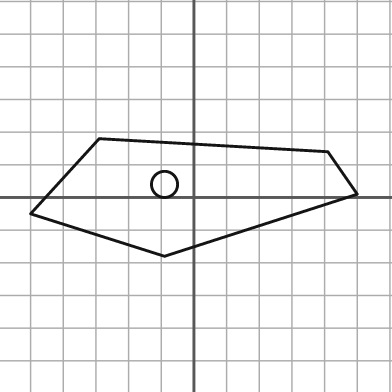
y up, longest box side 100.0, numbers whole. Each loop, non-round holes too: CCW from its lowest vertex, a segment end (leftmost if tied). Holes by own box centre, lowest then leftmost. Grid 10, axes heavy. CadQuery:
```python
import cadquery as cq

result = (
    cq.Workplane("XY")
    .moveTo(-9.0, -18.0)
    .lineTo(50.0, 1.0)
    .lineTo(41.0, 14.0)
    .lineTo(-29.0, 18.0)
    .lineTo(-50.0, -5.0)
    .close()
    .moveTo(-9.0, 4.0)
    .circle(4.0)
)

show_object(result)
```